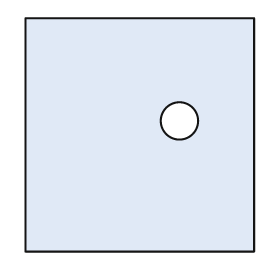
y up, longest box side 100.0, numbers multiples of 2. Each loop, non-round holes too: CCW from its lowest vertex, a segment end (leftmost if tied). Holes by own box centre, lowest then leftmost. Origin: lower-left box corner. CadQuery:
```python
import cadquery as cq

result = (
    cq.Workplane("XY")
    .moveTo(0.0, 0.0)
    .lineTo(98.0, 0.0)
    .lineTo(98.0, 100.0)
    .lineTo(0.0, 100.0)
    .close()
    .moveTo(66.0, 56.0)
    .circle(8.0)
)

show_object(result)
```